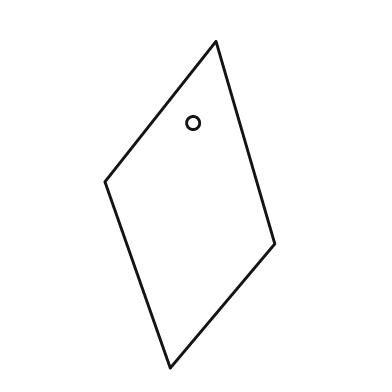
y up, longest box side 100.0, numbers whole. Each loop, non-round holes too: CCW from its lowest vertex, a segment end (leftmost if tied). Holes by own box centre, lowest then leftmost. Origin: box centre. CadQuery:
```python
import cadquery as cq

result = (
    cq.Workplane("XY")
    .moveTo(-6.0, -50.0)
    .lineTo(26.0, -12.0)
    .lineTo(8.0, 50.0)
    .lineTo(-26.0, 7.0)
    .close()
    .moveTo(1.0, 25.0)
    .circle(2.0)
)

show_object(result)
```